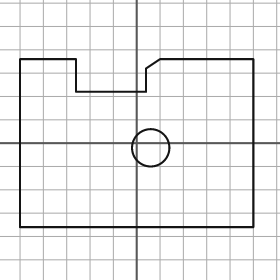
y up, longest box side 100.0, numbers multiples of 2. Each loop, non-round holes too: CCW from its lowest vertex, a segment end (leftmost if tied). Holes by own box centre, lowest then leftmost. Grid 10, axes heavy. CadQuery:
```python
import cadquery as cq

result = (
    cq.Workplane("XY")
    .moveTo(-50.0, -36.0)
    .lineTo(50.0, -36.0)
    .lineTo(50.0, 36.0)
    .lineTo(10.0, 36.0)
    .lineTo(4.0, 32.0)
    .lineTo(4.0, 22.0)
    .lineTo(-26.0, 22.0)
    .lineTo(-26.0, 36.0)
    .lineTo(-50.0, 36.0)
    .close()
    .moveTo(6.0, -2.0)
    .circle(8.0)
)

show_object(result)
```